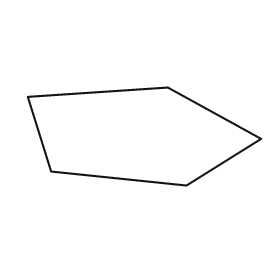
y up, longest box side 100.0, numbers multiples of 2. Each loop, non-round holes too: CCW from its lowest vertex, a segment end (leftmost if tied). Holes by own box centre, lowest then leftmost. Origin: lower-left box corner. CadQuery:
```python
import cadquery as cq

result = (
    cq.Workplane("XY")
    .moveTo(68.0, 0.0)
    .lineTo(100.0, 20.0)
    .lineTo(60.0, 42.0)
    .lineTo(0.0, 38.0)
    .lineTo(10.0, 6.0)
    .close()
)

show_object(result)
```